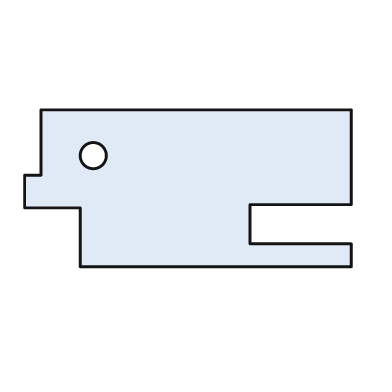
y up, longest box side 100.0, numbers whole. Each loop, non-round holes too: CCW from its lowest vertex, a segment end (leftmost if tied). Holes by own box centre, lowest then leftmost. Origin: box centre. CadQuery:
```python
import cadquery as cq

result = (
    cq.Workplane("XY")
    .moveTo(-33.0, -24.0)
    .lineTo(50.0, -24.0)
    .lineTo(50.0, -17.0)
    .lineTo(19.0, -17.0)
    .lineTo(19.0, -5.0)
    .lineTo(50.0, -5.0)
    .lineTo(50.0, 24.0)
    .lineTo(-45.0, 24.0)
    .lineTo(-45.0, 4.0)
    .lineTo(-50.0, 4.0)
    .lineTo(-50.0, -6.0)
    .lineTo(-33.0, -6.0)
    .close()
    .moveTo(-29.0, 10.0)
    .circle(4.0)
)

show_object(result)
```